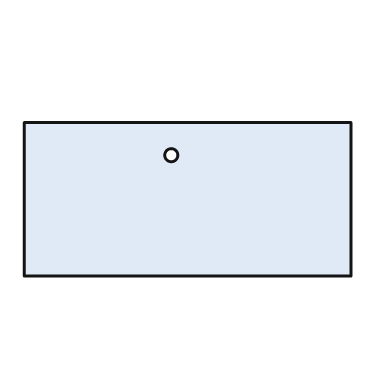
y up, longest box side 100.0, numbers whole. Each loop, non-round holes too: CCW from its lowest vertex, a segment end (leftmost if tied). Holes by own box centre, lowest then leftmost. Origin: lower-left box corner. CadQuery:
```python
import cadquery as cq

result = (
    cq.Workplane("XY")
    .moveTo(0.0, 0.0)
    .lineTo(100.0, 0.0)
    .lineTo(100.0, 47.0)
    .lineTo(0.0, 47.0)
    .close()
    .moveTo(45.0, 37.0)
    .circle(2.0)
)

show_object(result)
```